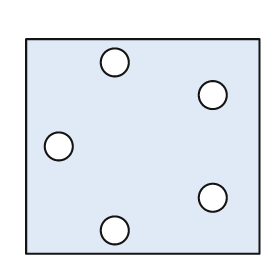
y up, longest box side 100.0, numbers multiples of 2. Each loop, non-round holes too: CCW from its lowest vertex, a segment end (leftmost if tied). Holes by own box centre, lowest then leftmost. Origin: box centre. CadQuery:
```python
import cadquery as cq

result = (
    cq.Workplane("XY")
    .moveTo(-50.0, -46.0)
    .lineTo(50.0, -46.0)
    .lineTo(50.0, 46.0)
    .lineTo(-50.0, 46.0)
    .close()
    .moveTo(-12.0, -36.0)
    .circle(6.0)
    .moveTo(30.0, -22.0)
    .circle(6.0)
    .moveTo(-36.0, 0.0)
    .circle(6.0)
    .moveTo(30.0, 22.0)
    .circle(6.0)
    .moveTo(-12.0, 36.0)
    .circle(6.0)
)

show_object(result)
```